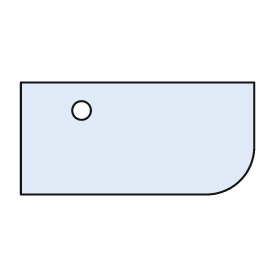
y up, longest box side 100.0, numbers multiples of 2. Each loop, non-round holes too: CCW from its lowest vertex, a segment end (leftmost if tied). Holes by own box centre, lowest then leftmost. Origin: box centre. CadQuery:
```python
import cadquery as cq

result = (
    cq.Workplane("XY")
    .moveTo(-50.0, -24.0)
    .lineTo(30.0, -24.0)
    .threePointArc((44.0, -18.0), (50.0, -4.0))
    .lineTo(50.0, 24.0)
    .lineTo(-50.0, 24.0)
    .close()
    .moveTo(-24.0, 12.0)
    .circle(4.0)
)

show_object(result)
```